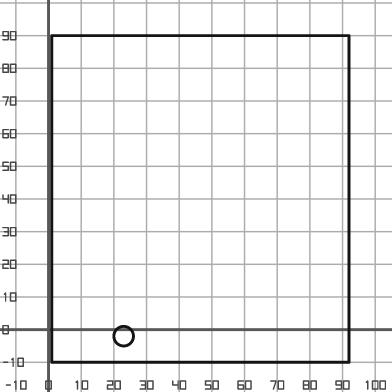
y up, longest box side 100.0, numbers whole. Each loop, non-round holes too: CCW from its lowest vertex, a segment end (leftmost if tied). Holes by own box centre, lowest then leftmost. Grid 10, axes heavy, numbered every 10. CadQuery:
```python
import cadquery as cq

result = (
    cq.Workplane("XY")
    .moveTo(1.0, -10.0)
    .lineTo(92.0, -10.0)
    .lineTo(92.0, 90.0)
    .lineTo(1.0, 90.0)
    .close()
    .moveTo(23.0, -2.0)
    .circle(3.0)
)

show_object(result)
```